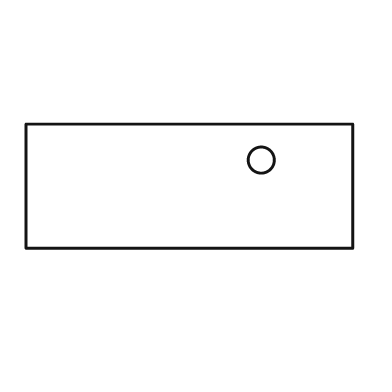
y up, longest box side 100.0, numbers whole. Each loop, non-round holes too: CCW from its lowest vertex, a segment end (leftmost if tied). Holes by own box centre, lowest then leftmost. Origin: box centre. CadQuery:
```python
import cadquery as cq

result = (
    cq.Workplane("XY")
    .moveTo(-50.0, -19.0)
    .lineTo(50.0, -19.0)
    .lineTo(50.0, 19.0)
    .lineTo(-50.0, 19.0)
    .close()
    .moveTo(22.0, 8.0)
    .circle(4.0)
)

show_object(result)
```